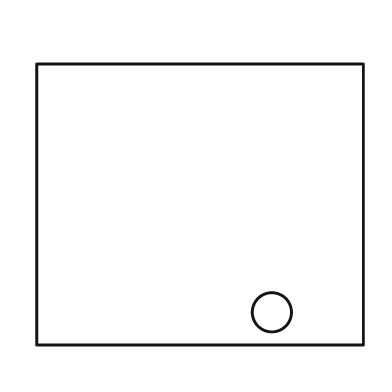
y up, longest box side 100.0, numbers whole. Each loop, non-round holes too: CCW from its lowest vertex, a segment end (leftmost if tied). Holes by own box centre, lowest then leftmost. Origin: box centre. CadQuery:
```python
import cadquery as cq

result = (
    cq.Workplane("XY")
    .moveTo(-50.0, -43.0)
    .lineTo(50.0, -43.0)
    .lineTo(50.0, 43.0)
    .lineTo(-50.0, 43.0)
    .close()
    .moveTo(22.0, -33.0)
    .circle(6.0)
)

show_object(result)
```